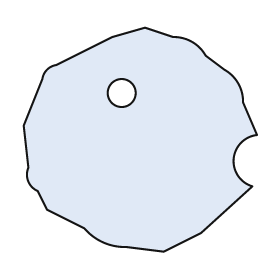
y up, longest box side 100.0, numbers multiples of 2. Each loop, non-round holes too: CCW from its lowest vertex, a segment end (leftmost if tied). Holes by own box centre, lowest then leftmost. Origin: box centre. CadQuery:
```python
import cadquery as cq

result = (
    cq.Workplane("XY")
    .moveTo(10.0, -48.0)
    .lineTo(26.0, -40.0)
    .lineTo(48.0, -20.0)
    .threePointArc((40.0, -8.0), (50.0, 2.0))
    .lineTo(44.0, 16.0)
    .threePointArc((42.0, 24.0), (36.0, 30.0))
    .lineTo(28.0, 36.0)
    .threePointArc((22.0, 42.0), (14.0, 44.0))
    .lineTo(2.0, 48.0)
    .lineTo(-12.0, 44.0)
    .lineTo(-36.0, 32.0)
    .threePointArc((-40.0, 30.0), (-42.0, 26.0))
    .lineTo(-50.0, 6.0)
    .lineTo(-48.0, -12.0)
    .threePointArc((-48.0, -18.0), (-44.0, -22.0))
    .lineTo(-40.0, -30.0)
    .lineTo(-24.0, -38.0)
    .threePointArc((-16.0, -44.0), (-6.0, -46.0))
    .close()
    .moveTo(-8.0, 20.0)
    .circle(6.0)
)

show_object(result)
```